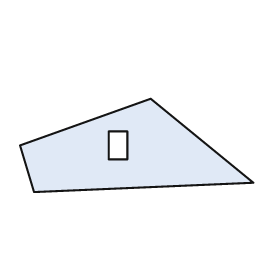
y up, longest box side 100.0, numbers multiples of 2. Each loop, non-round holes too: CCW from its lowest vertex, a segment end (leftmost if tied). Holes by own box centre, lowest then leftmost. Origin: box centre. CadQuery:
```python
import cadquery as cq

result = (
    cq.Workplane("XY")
    .moveTo(-44.0, -20.0)
    .lineTo(50.0, -16.0)
    .lineTo(6.0, 20.0)
    .lineTo(-50.0, 0.0)
    .close()
    .moveTo(-12.0, -6.0)
    .lineTo(-4.0, -6.0)
    .lineTo(-4.0, 6.0)
    .lineTo(-12.0, 6.0)
    .close()
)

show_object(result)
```